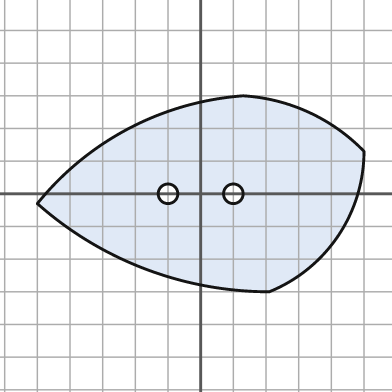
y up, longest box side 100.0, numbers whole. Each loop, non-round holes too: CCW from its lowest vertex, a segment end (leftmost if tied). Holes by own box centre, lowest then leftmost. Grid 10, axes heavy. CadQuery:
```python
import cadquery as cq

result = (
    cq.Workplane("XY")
    .moveTo(21.0, -30.0)
    .threePointArc((42.0, -13.0), (50.0, 13.0))
    .threePointArc((33.0, 25.0), (13.0, 30.0))
    .threePointArc((-22.0, 20.0), (-50.0, -3.0))
    .threePointArc((-17.0, -23.0), (21.0, -30.0))
    .close()
    .moveTo(-10.0, 0.0)
    .circle(3.0)
    .moveTo(10.0, 0.0)
    .circle(3.0)
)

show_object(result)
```